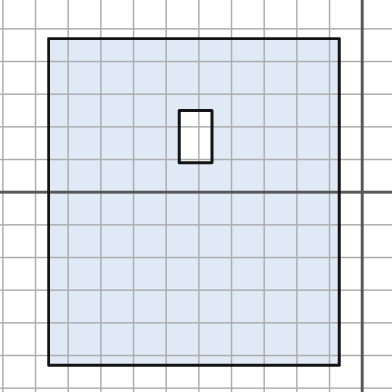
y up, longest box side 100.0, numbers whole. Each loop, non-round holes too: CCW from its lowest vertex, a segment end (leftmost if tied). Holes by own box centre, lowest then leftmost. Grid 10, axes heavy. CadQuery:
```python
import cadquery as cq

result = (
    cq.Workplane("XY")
    .moveTo(-96.0, -53.0)
    .lineTo(-7.0, -53.0)
    .lineTo(-7.0, 47.0)
    .lineTo(-96.0, 47.0)
    .close()
    .moveTo(-56.0, 9.0)
    .lineTo(-46.0, 9.0)
    .lineTo(-46.0, 25.0)
    .lineTo(-56.0, 25.0)
    .close()
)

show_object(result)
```